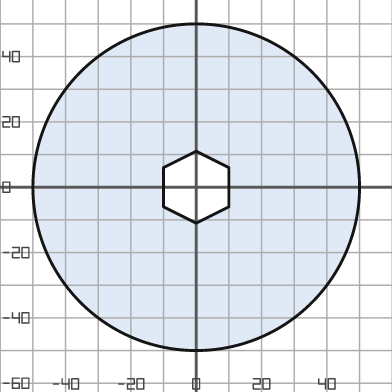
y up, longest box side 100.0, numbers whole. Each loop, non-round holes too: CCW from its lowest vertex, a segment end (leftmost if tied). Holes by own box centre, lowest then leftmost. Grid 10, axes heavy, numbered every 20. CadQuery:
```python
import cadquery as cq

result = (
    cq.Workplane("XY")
    .moveTo(0.0, 0.0)
    .circle(50.0)
    .moveTo(0.0, -11.0)
    .lineTo(10.0, -6.0)
    .lineTo(10.0, 6.0)
    .lineTo(0.0, 11.0)
    .lineTo(-10.0, 6.0)
    .lineTo(-10.0, -6.0)
    .close()
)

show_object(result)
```